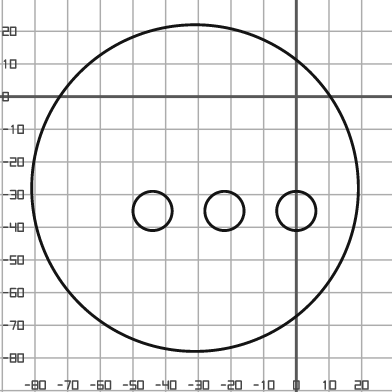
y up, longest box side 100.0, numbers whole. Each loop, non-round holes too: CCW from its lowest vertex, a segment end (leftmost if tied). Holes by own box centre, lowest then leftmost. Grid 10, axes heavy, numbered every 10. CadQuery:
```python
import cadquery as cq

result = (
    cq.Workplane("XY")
    .moveTo(-31.0, -28.0)
    .circle(50.0)
    .moveTo(-44.0, -35.0)
    .circle(6.0)
    .moveTo(-22.0, -35.0)
    .circle(6.0)
    .moveTo(0.0, -35.0)
    .circle(6.0)
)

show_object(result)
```